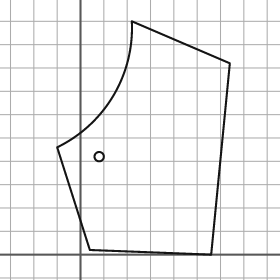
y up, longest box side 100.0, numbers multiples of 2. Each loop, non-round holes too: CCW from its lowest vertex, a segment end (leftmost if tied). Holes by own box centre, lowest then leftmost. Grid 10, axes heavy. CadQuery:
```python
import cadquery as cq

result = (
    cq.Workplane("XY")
    .moveTo(56.0, 0.0)
    .lineTo(64.0, 82.0)
    .lineTo(22.0, 100.0)
    .threePointArc((14.0, 68.0), (-10.0, 46.0))
    .lineTo(4.0, 2.0)
    .close()
    .moveTo(8.0, 42.0)
    .circle(2.0)
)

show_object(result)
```